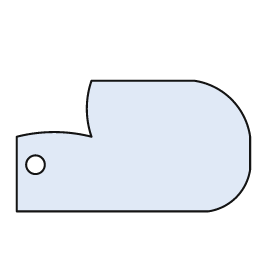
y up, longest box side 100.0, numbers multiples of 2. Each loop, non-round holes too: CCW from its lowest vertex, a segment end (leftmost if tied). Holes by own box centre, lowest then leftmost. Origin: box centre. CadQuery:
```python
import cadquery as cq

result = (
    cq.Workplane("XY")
    .moveTo(-50.0, -28.0)
    .lineTo(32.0, -28.0)
    .threePointArc((44.0, -22.0), (50.0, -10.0))
    .lineTo(50.0, 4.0)
    .threePointArc((42.0, 20.0), (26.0, 28.0))
    .lineTo(-18.0, 28.0)
    .threePointArc((-20.0, 16.0), (-18.0, 4.0))
    .threePointArc((-34.0, 6.0), (-50.0, 4.0))
    .close()
    .moveTo(-42.0, -8.0)
    .circle(4.0)
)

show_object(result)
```